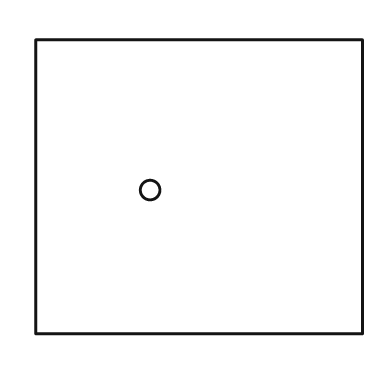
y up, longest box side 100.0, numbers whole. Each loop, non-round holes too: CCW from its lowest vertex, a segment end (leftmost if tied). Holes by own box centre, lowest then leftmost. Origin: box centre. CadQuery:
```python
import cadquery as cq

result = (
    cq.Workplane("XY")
    .moveTo(-50.0, -45.0)
    .lineTo(50.0, -45.0)
    .lineTo(50.0, 45.0)
    .lineTo(-50.0, 45.0)
    .close()
    .moveTo(-15.0, -1.0)
    .circle(3.0)
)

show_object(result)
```